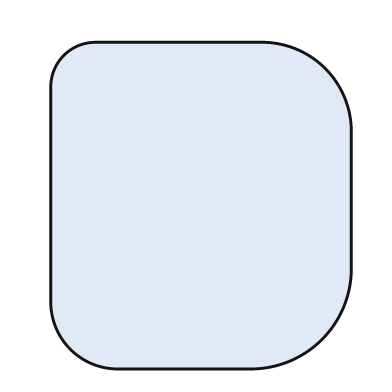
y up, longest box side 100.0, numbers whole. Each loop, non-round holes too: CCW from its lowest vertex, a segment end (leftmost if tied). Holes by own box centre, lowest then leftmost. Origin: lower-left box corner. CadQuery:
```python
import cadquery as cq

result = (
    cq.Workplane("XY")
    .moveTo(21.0, 0.0)
    .lineTo(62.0, 0.0)
    .threePointArc((83.0, 9.0), (92.0, 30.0))
    .lineTo(92.0, 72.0)
    .threePointArc((84.0, 92.0), (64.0, 100.0))
    .lineTo(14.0, 100.0)
    .threePointArc((4.0, 96.0), (0.0, 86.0))
    .lineTo(0.0, 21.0)
    .threePointArc((6.0, 6.0), (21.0, 0.0))
    .close()
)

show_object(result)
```